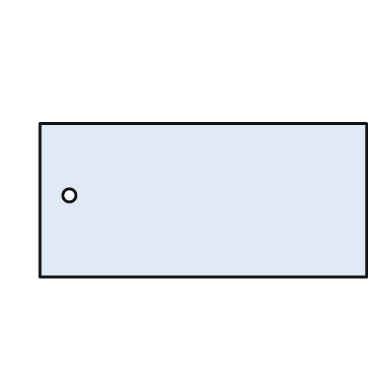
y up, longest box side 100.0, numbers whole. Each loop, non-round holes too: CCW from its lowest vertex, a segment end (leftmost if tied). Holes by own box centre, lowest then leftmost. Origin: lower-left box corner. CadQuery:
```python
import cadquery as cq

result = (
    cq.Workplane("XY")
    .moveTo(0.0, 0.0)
    .lineTo(100.0, 0.0)
    .lineTo(100.0, 47.0)
    .lineTo(0.0, 47.0)
    .close()
    .moveTo(9.0, 25.0)
    .circle(2.0)
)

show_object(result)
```